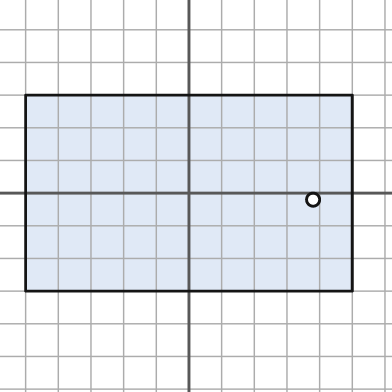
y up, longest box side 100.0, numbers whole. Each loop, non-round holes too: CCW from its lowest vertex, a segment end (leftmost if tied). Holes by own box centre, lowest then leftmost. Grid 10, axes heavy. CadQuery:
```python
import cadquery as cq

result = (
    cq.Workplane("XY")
    .moveTo(-50.0, -30.0)
    .lineTo(50.0, -30.0)
    .lineTo(50.0, 30.0)
    .lineTo(-50.0, 30.0)
    .close()
    .moveTo(38.0, -2.0)
    .circle(2.0)
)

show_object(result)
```